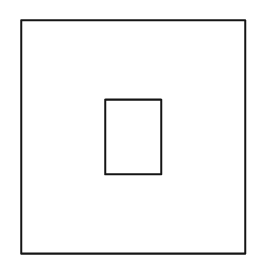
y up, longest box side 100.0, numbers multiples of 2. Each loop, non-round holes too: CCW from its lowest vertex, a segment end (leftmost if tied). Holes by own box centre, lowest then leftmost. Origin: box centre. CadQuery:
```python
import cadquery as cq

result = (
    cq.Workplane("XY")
    .moveTo(-48.0, -50.0)
    .lineTo(48.0, -50.0)
    .lineTo(48.0, 50.0)
    .lineTo(-48.0, 50.0)
    .close()
    .moveTo(-12.0, -16.0)
    .lineTo(12.0, -16.0)
    .lineTo(12.0, 16.0)
    .lineTo(-12.0, 16.0)
    .close()
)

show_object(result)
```